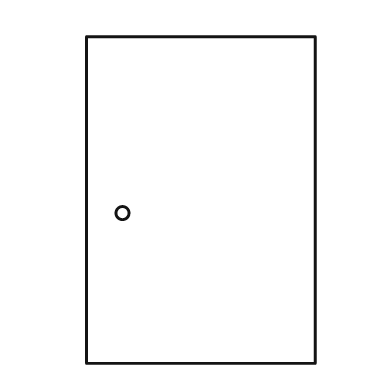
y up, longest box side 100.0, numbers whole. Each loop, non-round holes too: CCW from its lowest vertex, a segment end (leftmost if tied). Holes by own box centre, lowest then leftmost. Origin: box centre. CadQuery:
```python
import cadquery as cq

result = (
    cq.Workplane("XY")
    .moveTo(-35.0, -50.0)
    .lineTo(35.0, -50.0)
    .lineTo(35.0, 50.0)
    .lineTo(-35.0, 50.0)
    .close()
    .moveTo(-24.0, -4.0)
    .circle(2.0)
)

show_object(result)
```